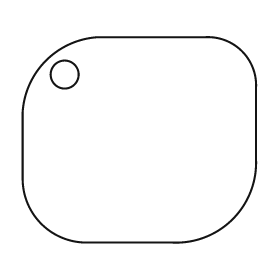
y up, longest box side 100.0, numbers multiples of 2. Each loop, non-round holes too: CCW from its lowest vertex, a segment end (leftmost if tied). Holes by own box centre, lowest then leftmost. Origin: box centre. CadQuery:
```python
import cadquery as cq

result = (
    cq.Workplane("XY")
    .moveTo(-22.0, -44.0)
    .lineTo(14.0, -44.0)
    .threePointArc((40.0, -34.0), (50.0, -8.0))
    .lineTo(50.0, 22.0)
    .threePointArc((44.0, 38.0), (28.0, 44.0))
    .lineTo(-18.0, 44.0)
    .threePointArc((-40.0, 34.0), (-50.0, 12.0))
    .lineTo(-50.0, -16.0)
    .threePointArc((-42.0, -36.0), (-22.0, -44.0))
    .close()
    .moveTo(-32.0, 28.0)
    .circle(6.0)
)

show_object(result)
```